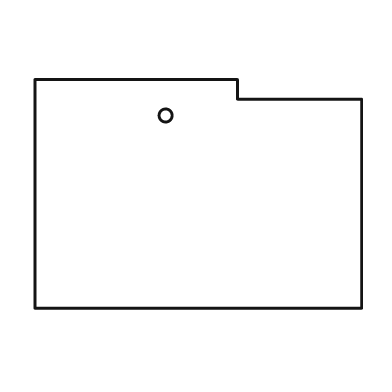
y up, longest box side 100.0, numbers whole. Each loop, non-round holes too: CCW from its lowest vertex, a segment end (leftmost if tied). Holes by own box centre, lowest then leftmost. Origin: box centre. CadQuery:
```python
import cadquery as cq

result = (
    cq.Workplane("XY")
    .moveTo(-50.0, -35.0)
    .lineTo(50.0, -35.0)
    .lineTo(50.0, 29.0)
    .lineTo(12.0, 29.0)
    .lineTo(12.0, 35.0)
    .lineTo(-50.0, 35.0)
    .close()
    .moveTo(-10.0, 24.0)
    .circle(2.0)
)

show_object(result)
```